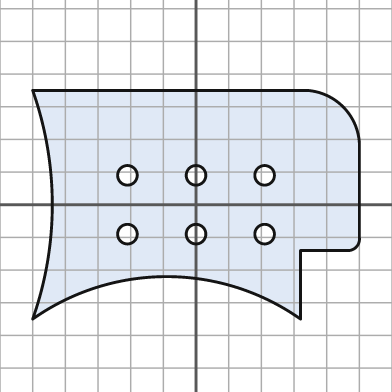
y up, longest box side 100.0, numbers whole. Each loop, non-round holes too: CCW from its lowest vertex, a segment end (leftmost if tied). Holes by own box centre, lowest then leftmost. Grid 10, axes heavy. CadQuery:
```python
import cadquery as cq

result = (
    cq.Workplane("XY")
    .moveTo(-50.0, -35.0)
    .threePointArc((-9.0, -22.0), (32.0, -35.0))
    .lineTo(32.0, -14.0)
    .lineTo(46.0, -14.0)
    .threePointArc((49.0, -13.0), (50.0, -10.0))
    .lineTo(50.0, 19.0)
    .threePointArc((45.0, 30.0), (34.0, 35.0))
    .lineTo(-50.0, 35.0)
    .threePointArc((-44.0, 0.0), (-50.0, -35.0))
    .close()
    .moveTo(-21.0, -9.0)
    .circle(3.0)
    .moveTo(0.0, -9.0)
    .circle(3.0)
    .moveTo(21.0, -9.0)
    .circle(3.0)
    .moveTo(-21.0, 9.0)
    .circle(3.0)
    .moveTo(0.0, 9.0)
    .circle(3.0)
    .moveTo(21.0, 9.0)
    .circle(3.0)
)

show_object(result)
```